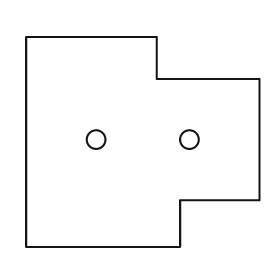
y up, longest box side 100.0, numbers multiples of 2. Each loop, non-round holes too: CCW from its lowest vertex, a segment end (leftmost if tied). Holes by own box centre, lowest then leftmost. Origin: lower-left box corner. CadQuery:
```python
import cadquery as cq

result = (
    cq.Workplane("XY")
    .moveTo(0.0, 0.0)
    .lineTo(66.0, 0.0)
    .lineTo(66.0, 20.0)
    .lineTo(100.0, 20.0)
    .lineTo(100.0, 72.0)
    .lineTo(56.0, 72.0)
    .lineTo(56.0, 90.0)
    .lineTo(0.0, 90.0)
    .close()
    .moveTo(30.0, 46.0)
    .circle(4.0)
    .moveTo(70.0, 46.0)
    .circle(4.0)
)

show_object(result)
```